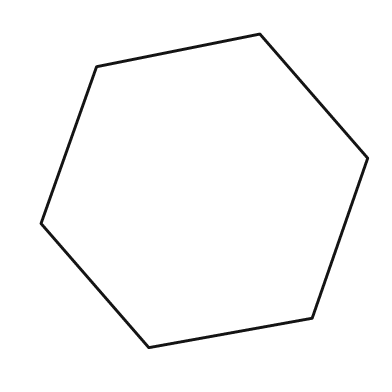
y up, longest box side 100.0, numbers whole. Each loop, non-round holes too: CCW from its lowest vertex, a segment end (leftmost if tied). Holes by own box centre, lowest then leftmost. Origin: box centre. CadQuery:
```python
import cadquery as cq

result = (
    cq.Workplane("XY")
    .moveTo(-17.0, -48.0)
    .lineTo(33.0, -39.0)
    .lineTo(50.0, 10.0)
    .lineTo(17.0, 48.0)
    .lineTo(-33.0, 38.0)
    .lineTo(-50.0, -10.0)
    .close()
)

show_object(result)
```